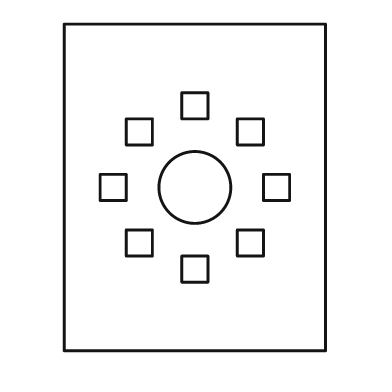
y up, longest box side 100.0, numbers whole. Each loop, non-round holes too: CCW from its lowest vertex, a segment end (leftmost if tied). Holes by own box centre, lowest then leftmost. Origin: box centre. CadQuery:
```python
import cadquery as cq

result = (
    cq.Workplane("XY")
    .moveTo(-40.0, -50.0)
    .lineTo(40.0, -50.0)
    .lineTo(40.0, 50.0)
    .lineTo(-40.0, 50.0)
    .close()
    .moveTo(-4.0, -29.0)
    .lineTo(4.0, -29.0)
    .lineTo(4.0, -21.0)
    .lineTo(-4.0, -21.0)
    .close()
    .moveTo(-21.0, -21.0)
    .lineTo(-13.0, -21.0)
    .lineTo(-13.0, -13.0)
    .lineTo(-21.0, -13.0)
    .close()
    .moveTo(13.0, -21.0)
    .lineTo(21.0, -21.0)
    .lineTo(21.0, -13.0)
    .lineTo(13.0, -13.0)
    .close()
    .moveTo(-29.0, -4.0)
    .lineTo(-21.0, -4.0)
    .lineTo(-21.0, 4.0)
    .lineTo(-29.0, 4.0)
    .close()
    .moveTo(0.0, 0.0)
    .circle(11.0)
    .moveTo(21.0, -4.0)
    .lineTo(29.0, -4.0)
    .lineTo(29.0, 4.0)
    .lineTo(21.0, 4.0)
    .close()
    .moveTo(-21.0, 13.0)
    .lineTo(-13.0, 13.0)
    .lineTo(-13.0, 21.0)
    .lineTo(-21.0, 21.0)
    .close()
    .moveTo(13.0, 13.0)
    .lineTo(21.0, 13.0)
    .lineTo(21.0, 21.0)
    .lineTo(13.0, 21.0)
    .close()
    .moveTo(-4.0, 21.0)
    .lineTo(4.0, 21.0)
    .lineTo(4.0, 29.0)
    .lineTo(-4.0, 29.0)
    .close()
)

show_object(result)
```